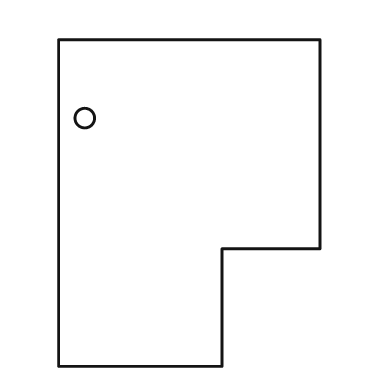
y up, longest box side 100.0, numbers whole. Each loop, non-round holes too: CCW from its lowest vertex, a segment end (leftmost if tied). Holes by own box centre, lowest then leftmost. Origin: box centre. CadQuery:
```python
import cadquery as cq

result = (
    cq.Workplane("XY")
    .moveTo(-40.0, -50.0)
    .lineTo(10.0, -50.0)
    .lineTo(10.0, -14.0)
    .lineTo(40.0, -14.0)
    .lineTo(40.0, 50.0)
    .lineTo(-40.0, 50.0)
    .close()
    .moveTo(-32.0, 26.0)
    .circle(3.0)
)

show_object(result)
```